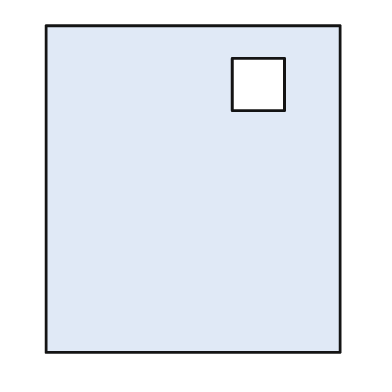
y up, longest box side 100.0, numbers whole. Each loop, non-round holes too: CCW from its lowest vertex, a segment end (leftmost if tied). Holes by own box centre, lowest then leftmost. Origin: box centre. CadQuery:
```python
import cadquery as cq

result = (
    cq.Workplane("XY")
    .moveTo(-45.0, -50.0)
    .lineTo(45.0, -50.0)
    .lineTo(45.0, 50.0)
    .lineTo(-45.0, 50.0)
    .close()
    .moveTo(12.0, 24.0)
    .lineTo(28.0, 24.0)
    .lineTo(28.0, 40.0)
    .lineTo(12.0, 40.0)
    .close()
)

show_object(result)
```